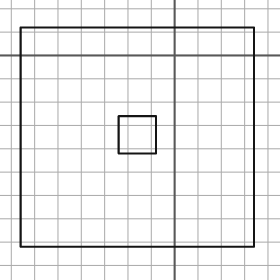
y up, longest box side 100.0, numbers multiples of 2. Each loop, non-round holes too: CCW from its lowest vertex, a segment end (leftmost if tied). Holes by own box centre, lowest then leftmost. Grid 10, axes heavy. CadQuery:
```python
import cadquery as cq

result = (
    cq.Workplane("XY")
    .moveTo(-66.0, -82.0)
    .lineTo(34.0, -82.0)
    .lineTo(34.0, 12.0)
    .lineTo(-66.0, 12.0)
    .close()
    .moveTo(-24.0, -42.0)
    .lineTo(-8.0, -42.0)
    .lineTo(-8.0, -26.0)
    .lineTo(-24.0, -26.0)
    .close()
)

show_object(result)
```